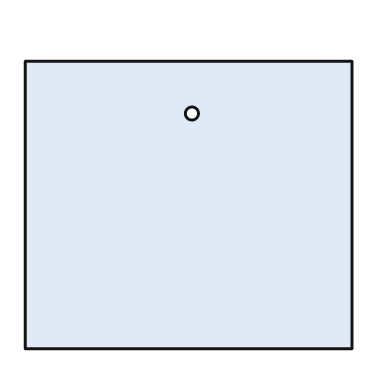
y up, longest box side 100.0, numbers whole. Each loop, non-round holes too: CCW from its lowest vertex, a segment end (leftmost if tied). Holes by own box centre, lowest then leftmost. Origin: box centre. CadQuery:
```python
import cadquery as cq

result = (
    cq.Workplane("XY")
    .moveTo(-50.0, -44.0)
    .lineTo(50.0, -44.0)
    .lineTo(50.0, 44.0)
    .lineTo(-50.0, 44.0)
    .close()
    .moveTo(1.0, 28.0)
    .circle(2.0)
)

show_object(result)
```